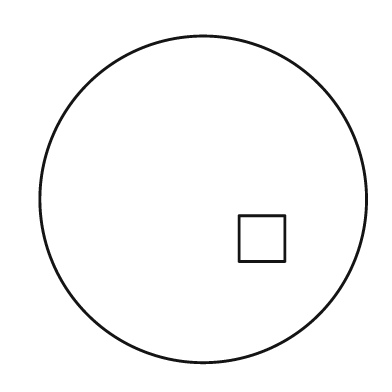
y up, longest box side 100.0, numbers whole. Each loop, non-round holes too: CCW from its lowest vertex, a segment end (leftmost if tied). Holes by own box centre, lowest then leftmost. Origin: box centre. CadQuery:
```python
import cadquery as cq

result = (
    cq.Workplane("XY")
    .moveTo(0.0, 0.0)
    .circle(50.0)
    .moveTo(11.0, -19.0)
    .lineTo(25.0, -19.0)
    .lineTo(25.0, -5.0)
    .lineTo(11.0, -5.0)
    .close()
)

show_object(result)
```